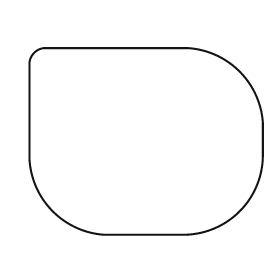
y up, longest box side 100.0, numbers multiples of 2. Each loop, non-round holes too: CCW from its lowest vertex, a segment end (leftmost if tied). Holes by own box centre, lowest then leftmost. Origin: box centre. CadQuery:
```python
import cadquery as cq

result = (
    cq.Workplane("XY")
    .moveTo(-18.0, -40.0)
    .lineTo(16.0, -40.0)
    .threePointArc((40.0, -30.0), (50.0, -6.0))
    .lineTo(50.0, 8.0)
    .threePointArc((40.0, 30.0), (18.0, 40.0))
    .lineTo(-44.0, 40.0)
    .threePointArc((-48.0, 38.0), (-50.0, 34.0))
    .lineTo(-50.0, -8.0)
    .threePointArc((-40.0, -30.0), (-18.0, -40.0))
    .close()
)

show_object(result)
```